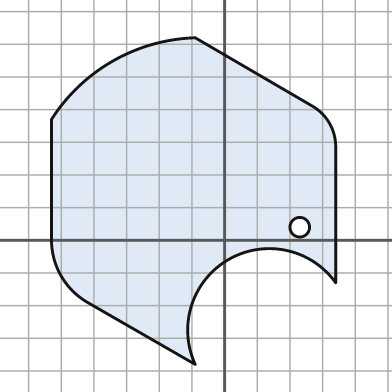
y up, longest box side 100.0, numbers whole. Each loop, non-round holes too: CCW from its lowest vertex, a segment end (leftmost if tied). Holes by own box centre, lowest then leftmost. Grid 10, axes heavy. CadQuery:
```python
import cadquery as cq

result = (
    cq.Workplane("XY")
    .moveTo(-9.0, -38.0)
    .threePointArc((1.0, -6.0), (34.0, -13.0))
    .lineTo(34.0, 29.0)
    .threePointArc((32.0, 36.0), (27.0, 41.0))
    .lineTo(-9.0, 62.0)
    .threePointArc((-34.0, 55.0), (-53.0, 37.0))
    .lineTo(-53.0, 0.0)
    .threePointArc((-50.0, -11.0), (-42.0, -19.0))
    .close()
    .moveTo(23.0, 4.0)
    .circle(3.0)
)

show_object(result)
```